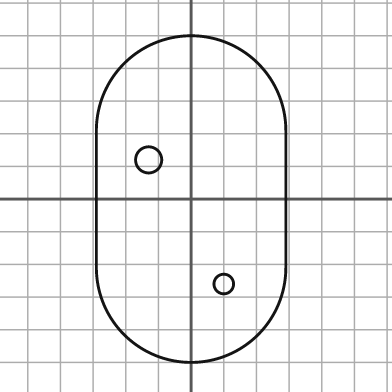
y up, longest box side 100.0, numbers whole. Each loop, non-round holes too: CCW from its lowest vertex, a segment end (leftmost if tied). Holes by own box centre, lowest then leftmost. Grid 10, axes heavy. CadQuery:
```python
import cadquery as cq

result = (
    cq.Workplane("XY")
    .moveTo(-29.0, -21.0)
    .threePointArc((0.0, -50.0), (29.0, -21.0))
    .lineTo(29.0, 21.0)
    .threePointArc((0.0, 50.0), (-29.0, 21.0))
    .close()
    .moveTo(10.0, -26.0)
    .circle(3.0)
    .moveTo(-13.0, 12.0)
    .circle(4.0)
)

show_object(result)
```